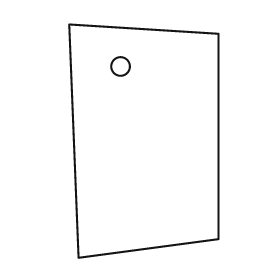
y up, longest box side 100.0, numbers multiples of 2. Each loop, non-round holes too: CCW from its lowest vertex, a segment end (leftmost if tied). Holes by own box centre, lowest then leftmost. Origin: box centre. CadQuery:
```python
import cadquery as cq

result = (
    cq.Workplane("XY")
    .moveTo(-28.0, -50.0)
    .lineTo(32.0, -42.0)
    .lineTo(32.0, 46.0)
    .lineTo(-32.0, 50.0)
    .close()
    .moveTo(-10.0, 32.0)
    .circle(4.0)
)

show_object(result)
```